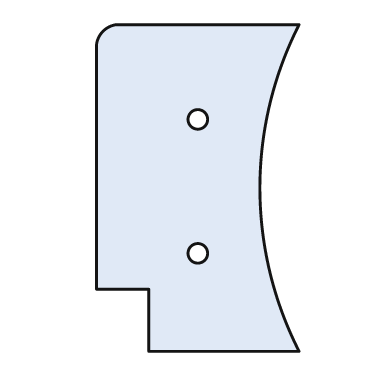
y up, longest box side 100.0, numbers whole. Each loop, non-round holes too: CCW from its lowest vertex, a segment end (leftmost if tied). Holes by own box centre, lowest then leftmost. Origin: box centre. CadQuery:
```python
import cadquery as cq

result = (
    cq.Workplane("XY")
    .moveTo(-15.0, -50.0)
    .lineTo(31.0, -50.0)
    .threePointArc((19.0, 0.0), (31.0, 50.0))
    .lineTo(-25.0, 50.0)
    .threePointArc((-29.0, 48.0), (-31.0, 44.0))
    .lineTo(-31.0, -31.0)
    .lineTo(-15.0, -31.0)
    .close()
    .moveTo(0.0, -20.0)
    .circle(3.0)
    .moveTo(0.0, 21.0)
    .circle(3.0)
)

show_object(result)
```